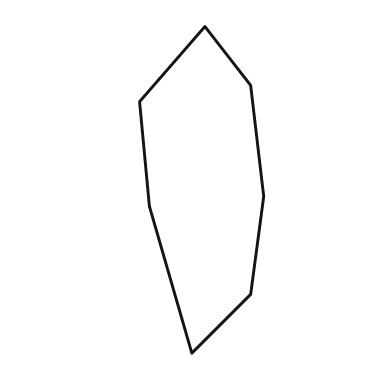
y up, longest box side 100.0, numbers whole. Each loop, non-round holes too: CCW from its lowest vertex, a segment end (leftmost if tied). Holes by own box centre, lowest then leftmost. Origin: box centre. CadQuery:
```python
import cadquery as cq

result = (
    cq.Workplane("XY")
    .moveTo(-3.0, -50.0)
    .lineTo(15.0, -32.0)
    .lineTo(19.0, -2.0)
    .lineTo(15.0, 32.0)
    .lineTo(1.0, 50.0)
    .lineTo(-19.0, 27.0)
    .lineTo(-16.0, -5.0)
    .close()
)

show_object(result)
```